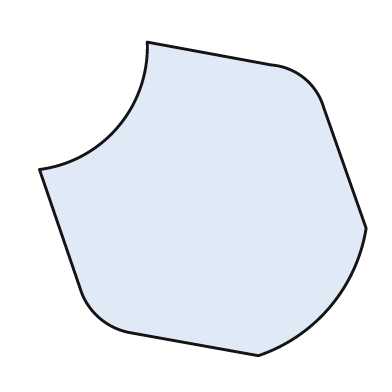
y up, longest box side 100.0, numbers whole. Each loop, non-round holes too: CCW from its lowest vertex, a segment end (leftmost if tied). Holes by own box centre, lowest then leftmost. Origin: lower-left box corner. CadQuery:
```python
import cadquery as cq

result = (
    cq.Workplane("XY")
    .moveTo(67.0, 0.0)
    .threePointArc((89.0, 15.0), (100.0, 39.0))
    .lineTo(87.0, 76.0)
    .threePointArc((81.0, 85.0), (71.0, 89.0))
    .lineTo(33.0, 96.0)
    .threePointArc((24.0, 70.0), (0.0, 57.0))
    .lineTo(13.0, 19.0)
    .threePointArc((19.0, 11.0), (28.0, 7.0))
    .close()
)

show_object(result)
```